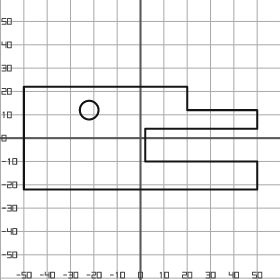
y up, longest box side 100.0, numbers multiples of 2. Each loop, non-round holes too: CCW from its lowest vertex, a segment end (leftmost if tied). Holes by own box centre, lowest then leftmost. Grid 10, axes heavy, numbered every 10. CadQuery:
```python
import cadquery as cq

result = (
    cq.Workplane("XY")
    .moveTo(-50.0, -22.0)
    .lineTo(50.0, -22.0)
    .lineTo(50.0, -10.0)
    .lineTo(2.0, -10.0)
    .lineTo(2.0, 4.0)
    .lineTo(50.0, 4.0)
    .lineTo(50.0, 12.0)
    .lineTo(20.0, 12.0)
    .lineTo(20.0, 22.0)
    .lineTo(-50.0, 22.0)
    .close()
    .moveTo(-22.0, 12.0)
    .circle(4.0)
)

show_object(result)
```